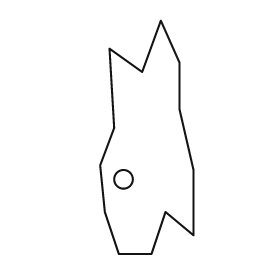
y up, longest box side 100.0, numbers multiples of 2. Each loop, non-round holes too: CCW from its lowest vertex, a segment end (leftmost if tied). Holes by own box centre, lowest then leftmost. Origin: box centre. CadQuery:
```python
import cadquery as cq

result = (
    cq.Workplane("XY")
    .moveTo(-12.0, -50.0)
    .lineTo(2.0, -50.0)
    .lineTo(8.0, -32.0)
    .lineTo(20.0, -42.0)
    .lineTo(20.0, -14.0)
    .lineTo(14.0, 12.0)
    .lineTo(14.0, 32.0)
    .lineTo(6.0, 50.0)
    .lineTo(-2.0, 28.0)
    .lineTo(-16.0, 38.0)
    .lineTo(-14.0, 4.0)
    .lineTo(-20.0, -12.0)
    .lineTo(-18.0, -32.0)
    .close()
    .moveTo(-10.0, -18.0)
    .circle(4.0)
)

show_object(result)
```